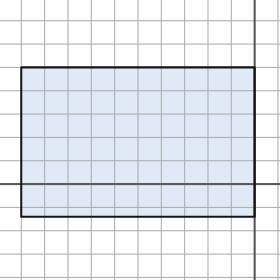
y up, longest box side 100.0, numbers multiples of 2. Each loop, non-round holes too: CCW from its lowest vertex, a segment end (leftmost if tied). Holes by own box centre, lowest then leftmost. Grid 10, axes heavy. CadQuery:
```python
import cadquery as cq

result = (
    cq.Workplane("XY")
    .moveTo(-100.0, -14.0)
    .lineTo(0.0, -14.0)
    .lineTo(0.0, 50.0)
    .lineTo(-100.0, 50.0)
    .close()
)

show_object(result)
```